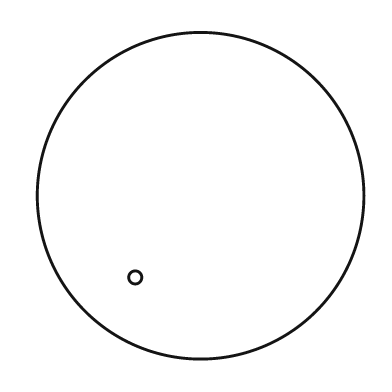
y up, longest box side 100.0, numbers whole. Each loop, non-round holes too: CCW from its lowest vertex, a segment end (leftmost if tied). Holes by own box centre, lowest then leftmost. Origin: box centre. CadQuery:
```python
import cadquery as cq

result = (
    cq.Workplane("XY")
    .moveTo(0.0, 0.0)
    .circle(50.0)
    .moveTo(-20.0, -25.0)
    .circle(2.0)
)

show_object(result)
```